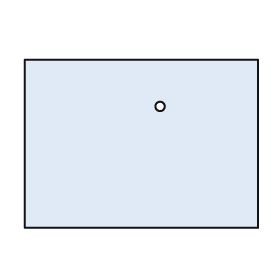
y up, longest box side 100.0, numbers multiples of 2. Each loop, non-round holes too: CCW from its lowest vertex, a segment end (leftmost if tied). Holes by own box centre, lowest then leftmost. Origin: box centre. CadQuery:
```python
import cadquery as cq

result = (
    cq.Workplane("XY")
    .moveTo(-50.0, -36.0)
    .lineTo(50.0, -36.0)
    .lineTo(50.0, 36.0)
    .lineTo(-50.0, 36.0)
    .close()
    .moveTo(8.0, 16.0)
    .circle(2.0)
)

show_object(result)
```